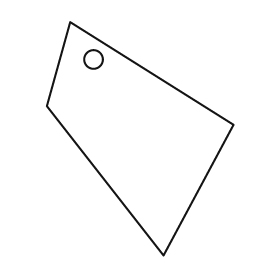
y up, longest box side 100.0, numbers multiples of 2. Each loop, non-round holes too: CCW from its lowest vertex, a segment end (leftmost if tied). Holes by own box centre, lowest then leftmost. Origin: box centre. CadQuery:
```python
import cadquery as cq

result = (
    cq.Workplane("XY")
    .moveTo(10.0, -50.0)
    .lineTo(40.0, 6.0)
    .lineTo(-30.0, 50.0)
    .lineTo(-40.0, 14.0)
    .close()
    .moveTo(-20.0, 34.0)
    .circle(4.0)
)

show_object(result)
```